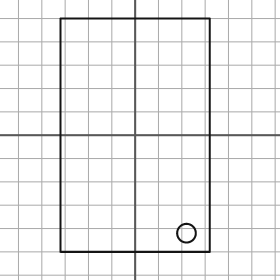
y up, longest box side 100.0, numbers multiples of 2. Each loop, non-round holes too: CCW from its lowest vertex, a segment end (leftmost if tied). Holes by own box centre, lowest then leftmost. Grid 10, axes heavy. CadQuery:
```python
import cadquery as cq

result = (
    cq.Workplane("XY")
    .moveTo(-32.0, -50.0)
    .lineTo(32.0, -50.0)
    .lineTo(32.0, 50.0)
    .lineTo(-32.0, 50.0)
    .close()
    .moveTo(22.0, -42.0)
    .circle(4.0)
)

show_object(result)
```